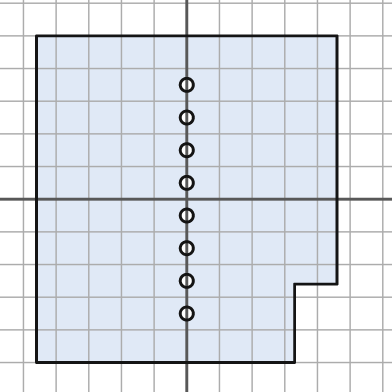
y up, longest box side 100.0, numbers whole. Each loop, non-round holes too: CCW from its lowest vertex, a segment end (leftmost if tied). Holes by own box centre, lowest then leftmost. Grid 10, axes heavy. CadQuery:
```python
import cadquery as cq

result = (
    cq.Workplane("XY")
    .moveTo(-46.0, -50.0)
    .lineTo(33.0, -50.0)
    .lineTo(33.0, -26.0)
    .lineTo(46.0, -26.0)
    .lineTo(46.0, 50.0)
    .lineTo(-46.0, 50.0)
    .close()
    .moveTo(0.0, -35.0)
    .circle(2.0)
    .moveTo(0.0, -25.0)
    .circle(2.0)
    .moveTo(0.0, -15.0)
    .circle(2.0)
    .moveTo(0.0, -5.0)
    .circle(2.0)
    .moveTo(0.0, 5.0)
    .circle(2.0)
    .moveTo(0.0, 15.0)
    .circle(2.0)
    .moveTo(0.0, 25.0)
    .circle(2.0)
    .moveTo(0.0, 35.0)
    .circle(2.0)
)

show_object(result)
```